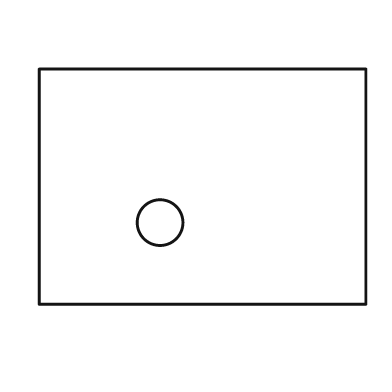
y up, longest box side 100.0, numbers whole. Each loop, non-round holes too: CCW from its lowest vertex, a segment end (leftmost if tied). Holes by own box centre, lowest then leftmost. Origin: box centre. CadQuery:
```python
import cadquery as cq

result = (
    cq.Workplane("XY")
    .moveTo(-50.0, -36.0)
    .lineTo(50.0, -36.0)
    .lineTo(50.0, 36.0)
    .lineTo(-50.0, 36.0)
    .close()
    .moveTo(-13.0, -11.0)
    .circle(7.0)
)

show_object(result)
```